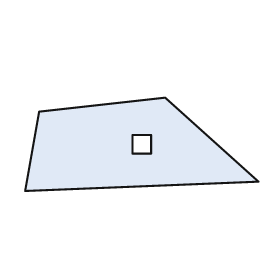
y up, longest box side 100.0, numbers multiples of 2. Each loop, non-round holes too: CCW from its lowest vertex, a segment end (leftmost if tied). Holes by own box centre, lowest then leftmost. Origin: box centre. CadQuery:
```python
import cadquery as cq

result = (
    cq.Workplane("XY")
    .moveTo(-50.0, -20.0)
    .lineTo(50.0, -16.0)
    .lineTo(10.0, 20.0)
    .lineTo(-44.0, 14.0)
    .close()
    .moveTo(-4.0, -4.0)
    .lineTo(4.0, -4.0)
    .lineTo(4.0, 4.0)
    .lineTo(-4.0, 4.0)
    .close()
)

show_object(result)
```